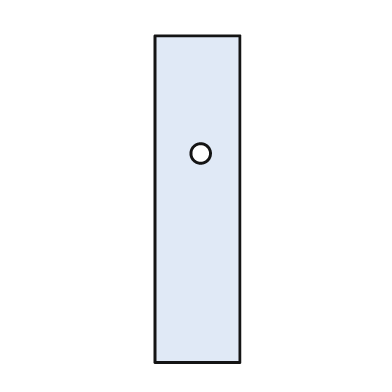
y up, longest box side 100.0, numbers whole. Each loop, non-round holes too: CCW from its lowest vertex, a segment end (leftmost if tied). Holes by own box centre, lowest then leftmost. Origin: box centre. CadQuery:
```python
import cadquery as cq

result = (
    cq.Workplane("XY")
    .moveTo(-13.0, -50.0)
    .lineTo(13.0, -50.0)
    .lineTo(13.0, 50.0)
    .lineTo(-13.0, 50.0)
    .close()
    .moveTo(1.0, 14.0)
    .circle(3.0)
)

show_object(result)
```